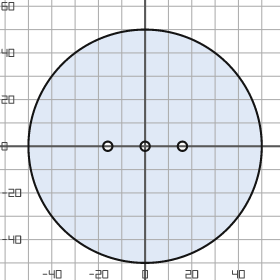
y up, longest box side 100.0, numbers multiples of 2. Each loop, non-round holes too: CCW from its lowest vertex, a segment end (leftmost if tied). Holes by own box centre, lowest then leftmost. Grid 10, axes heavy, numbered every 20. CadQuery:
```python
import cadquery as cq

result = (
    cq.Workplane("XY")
    .moveTo(0.0, 0.0)
    .circle(50.0)
    .moveTo(-16.0, 0.0)
    .circle(2.0)
    .moveTo(0.0, 0.0)
    .circle(2.0)
    .moveTo(16.0, 0.0)
    .circle(2.0)
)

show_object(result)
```